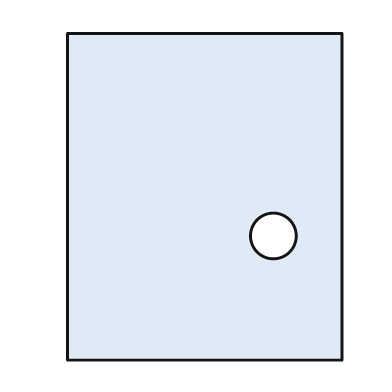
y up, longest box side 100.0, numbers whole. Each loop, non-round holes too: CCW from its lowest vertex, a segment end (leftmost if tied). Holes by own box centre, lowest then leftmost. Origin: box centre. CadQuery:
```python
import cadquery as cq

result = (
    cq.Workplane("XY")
    .moveTo(-42.0, -50.0)
    .lineTo(42.0, -50.0)
    .lineTo(42.0, 50.0)
    .lineTo(-42.0, 50.0)
    .close()
    .moveTo(21.0, -12.0)
    .circle(7.0)
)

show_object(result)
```